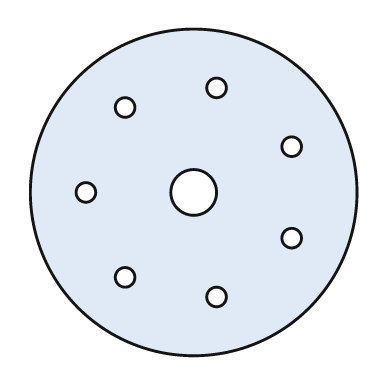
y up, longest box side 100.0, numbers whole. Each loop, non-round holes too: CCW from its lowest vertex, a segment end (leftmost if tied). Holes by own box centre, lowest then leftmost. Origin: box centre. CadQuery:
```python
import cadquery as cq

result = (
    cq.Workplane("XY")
    .moveTo(0.0, 0.0)
    .circle(50.0)
    .moveTo(7.0, -32.0)
    .circle(3.0)
    .moveTo(-21.0, -26.0)
    .circle(3.0)
    .moveTo(30.0, -14.0)
    .circle(3.0)
    .moveTo(-33.0, 0.0)
    .circle(3.0)
    .moveTo(0.0, 0.0)
    .circle(7.0)
    .moveTo(30.0, 14.0)
    .circle(3.0)
    .moveTo(-21.0, 26.0)
    .circle(3.0)
    .moveTo(7.0, 32.0)
    .circle(3.0)
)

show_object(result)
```